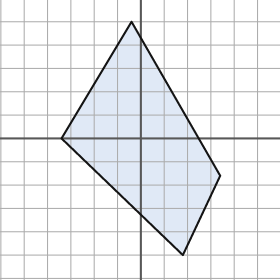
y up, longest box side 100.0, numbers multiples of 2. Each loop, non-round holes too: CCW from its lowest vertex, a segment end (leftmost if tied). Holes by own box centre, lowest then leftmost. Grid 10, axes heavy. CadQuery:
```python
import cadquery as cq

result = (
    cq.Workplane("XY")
    .moveTo(18.0, -50.0)
    .lineTo(34.0, -16.0)
    .lineTo(-4.0, 50.0)
    .lineTo(-34.0, 0.0)
    .close()
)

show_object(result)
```